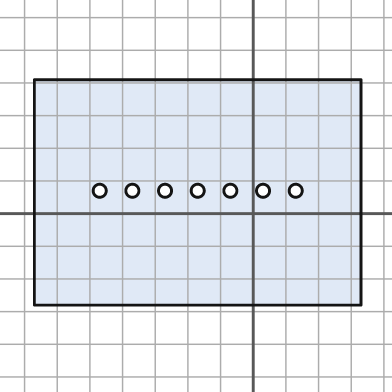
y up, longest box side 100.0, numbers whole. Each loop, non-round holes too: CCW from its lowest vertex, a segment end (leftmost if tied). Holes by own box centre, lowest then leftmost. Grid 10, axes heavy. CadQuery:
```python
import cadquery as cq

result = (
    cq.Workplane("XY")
    .moveTo(-67.0, -28.0)
    .lineTo(33.0, -28.0)
    .lineTo(33.0, 41.0)
    .lineTo(-67.0, 41.0)
    .close()
    .moveTo(-47.0, 7.0)
    .circle(2.0)
    .moveTo(-37.0, 7.0)
    .circle(2.0)
    .moveTo(-27.0, 7.0)
    .circle(2.0)
    .moveTo(-17.0, 7.0)
    .circle(2.0)
    .moveTo(-7.0, 7.0)
    .circle(2.0)
    .moveTo(3.0, 7.0)
    .circle(2.0)
    .moveTo(13.0, 7.0)
    .circle(2.0)
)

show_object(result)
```